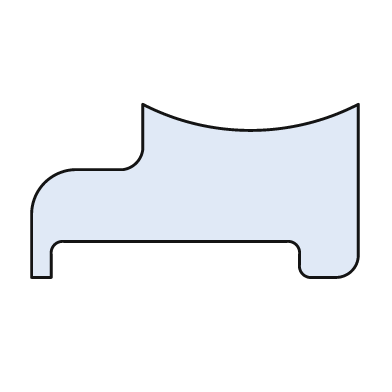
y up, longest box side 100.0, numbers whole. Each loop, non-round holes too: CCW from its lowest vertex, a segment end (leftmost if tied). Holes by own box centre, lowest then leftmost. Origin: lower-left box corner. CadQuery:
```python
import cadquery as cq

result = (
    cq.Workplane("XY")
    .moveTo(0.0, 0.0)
    .lineTo(6.0, 0.0)
    .lineTo(6.0, 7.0)
    .threePointArc((7.0, 10.0), (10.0, 11.0))
    .lineTo(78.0, 11.0)
    .threePointArc((81.0, 10.0), (82.0, 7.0))
    .lineTo(82.0, 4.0)
    .threePointArc((83.0, 1.0), (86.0, 0.0))
    .lineTo(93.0, 0.0)
    .threePointArc((98.0, 2.0), (100.0, 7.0))
    .lineTo(100.0, 53.0)
    .threePointArc((67.0, 45.0), (34.0, 53.0))
    .lineTo(34.0, 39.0)
    .threePointArc((32.0, 35.0), (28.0, 33.0))
    .lineTo(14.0, 33.0)
    .threePointArc((4.0, 29.0), (0.0, 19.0))
    .close()
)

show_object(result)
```